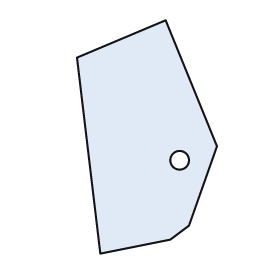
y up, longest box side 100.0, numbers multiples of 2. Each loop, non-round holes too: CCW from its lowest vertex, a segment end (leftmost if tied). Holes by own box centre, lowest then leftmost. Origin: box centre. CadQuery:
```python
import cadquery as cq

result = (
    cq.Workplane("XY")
    .moveTo(-20.0, -50.0)
    .lineTo(10.0, -44.0)
    .lineTo(18.0, -38.0)
    .lineTo(30.0, -4.0)
    .lineTo(8.0, 50.0)
    .lineTo(-30.0, 34.0)
    .close()
    .moveTo(14.0, -10.0)
    .circle(4.0)
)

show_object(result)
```